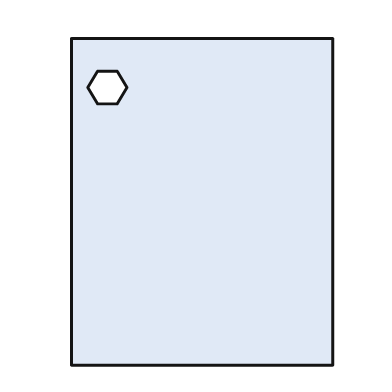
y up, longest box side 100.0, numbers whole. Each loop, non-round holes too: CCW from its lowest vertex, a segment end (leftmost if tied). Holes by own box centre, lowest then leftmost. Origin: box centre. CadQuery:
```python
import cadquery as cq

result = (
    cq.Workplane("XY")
    .moveTo(-40.0, -50.0)
    .lineTo(40.0, -50.0)
    .lineTo(40.0, 50.0)
    .lineTo(-40.0, 50.0)
    .close()
    .moveTo(-32.0, 30.0)
    .lineTo(-26.0, 30.0)
    .lineTo(-23.0, 35.0)
    .lineTo(-26.0, 40.0)
    .lineTo(-32.0, 40.0)
    .lineTo(-35.0, 35.0)
    .close()
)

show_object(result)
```